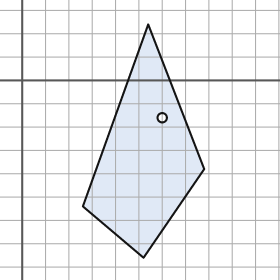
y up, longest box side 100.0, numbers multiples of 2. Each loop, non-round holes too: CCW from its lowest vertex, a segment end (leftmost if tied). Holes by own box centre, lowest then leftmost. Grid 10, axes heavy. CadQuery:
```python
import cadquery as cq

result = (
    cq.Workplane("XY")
    .moveTo(52.0, -76.0)
    .lineTo(78.0, -38.0)
    .lineTo(54.0, 24.0)
    .lineTo(26.0, -54.0)
    .close()
    .moveTo(60.0, -16.0)
    .circle(2.0)
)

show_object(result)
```